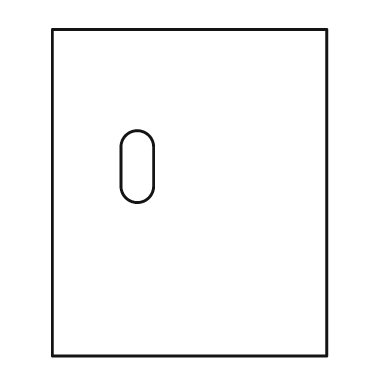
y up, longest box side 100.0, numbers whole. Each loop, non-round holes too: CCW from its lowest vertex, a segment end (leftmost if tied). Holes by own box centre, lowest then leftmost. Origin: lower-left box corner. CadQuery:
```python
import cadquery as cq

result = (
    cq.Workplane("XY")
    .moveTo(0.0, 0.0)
    .lineTo(84.0, 0.0)
    .lineTo(84.0, 100.0)
    .lineTo(0.0, 100.0)
    .close()
    .moveTo(21.0, 52.0)
    .threePointArc((26.0, 47.0), (31.0, 52.0))
    .lineTo(31.0, 64.0)
    .threePointArc((26.0, 69.0), (21.0, 64.0))
    .close()
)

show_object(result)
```